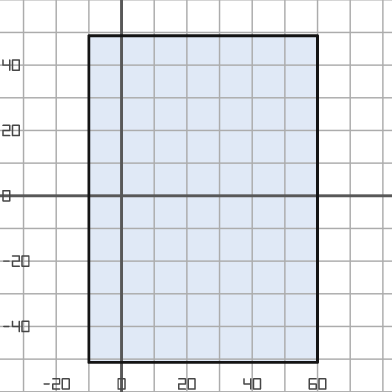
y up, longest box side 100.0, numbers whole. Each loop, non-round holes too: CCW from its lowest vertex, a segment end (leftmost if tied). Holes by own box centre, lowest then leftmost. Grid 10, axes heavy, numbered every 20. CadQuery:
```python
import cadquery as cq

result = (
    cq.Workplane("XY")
    .moveTo(-10.0, -51.0)
    .lineTo(60.0, -51.0)
    .lineTo(60.0, 49.0)
    .lineTo(-10.0, 49.0)
    .close()
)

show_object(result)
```